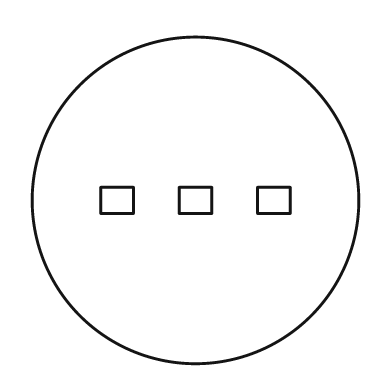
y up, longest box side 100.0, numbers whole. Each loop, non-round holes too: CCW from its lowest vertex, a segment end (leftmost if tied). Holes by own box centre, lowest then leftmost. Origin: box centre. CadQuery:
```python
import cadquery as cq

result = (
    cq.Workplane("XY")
    .moveTo(0.0, 0.0)
    .circle(50.0)
    .moveTo(-29.0, -4.0)
    .lineTo(-19.0, -4.0)
    .lineTo(-19.0, 4.0)
    .lineTo(-29.0, 4.0)
    .close()
    .moveTo(-5.0, -4.0)
    .lineTo(5.0, -4.0)
    .lineTo(5.0, 4.0)
    .lineTo(-5.0, 4.0)
    .close()
    .moveTo(19.0, -4.0)
    .lineTo(29.0, -4.0)
    .lineTo(29.0, 4.0)
    .lineTo(19.0, 4.0)
    .close()
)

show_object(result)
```